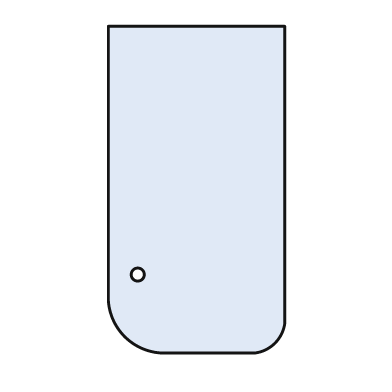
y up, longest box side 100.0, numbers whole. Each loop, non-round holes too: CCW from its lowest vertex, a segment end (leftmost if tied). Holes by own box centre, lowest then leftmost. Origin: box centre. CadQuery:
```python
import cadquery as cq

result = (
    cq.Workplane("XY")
    .moveTo(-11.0, -50.0)
    .lineTo(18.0, -50.0)
    .threePointArc((24.0, -47.0), (27.0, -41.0))
    .lineTo(27.0, 50.0)
    .lineTo(-27.0, 50.0)
    .lineTo(-27.0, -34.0)
    .threePointArc((-22.0, -45.0), (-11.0, -50.0))
    .close()
    .moveTo(-18.0, -26.0)
    .circle(2.0)
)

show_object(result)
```